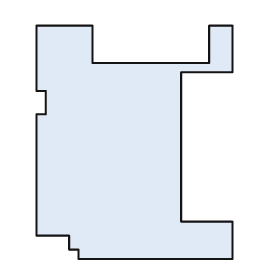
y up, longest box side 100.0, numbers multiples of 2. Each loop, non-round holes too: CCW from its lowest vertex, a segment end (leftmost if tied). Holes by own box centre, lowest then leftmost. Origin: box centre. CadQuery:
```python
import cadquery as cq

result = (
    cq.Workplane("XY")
    .moveTo(-24.0, -50.0)
    .lineTo(42.0, -50.0)
    .lineTo(42.0, -34.0)
    .lineTo(20.0, -34.0)
    .lineTo(20.0, 30.0)
    .lineTo(42.0, 30.0)
    .lineTo(42.0, 50.0)
    .lineTo(32.0, 50.0)
    .lineTo(32.0, 34.0)
    .lineTo(-18.0, 34.0)
    .lineTo(-18.0, 50.0)
    .lineTo(-42.0, 50.0)
    .lineTo(-42.0, 22.0)
    .lineTo(-38.0, 22.0)
    .lineTo(-38.0, 12.0)
    .lineTo(-42.0, 12.0)
    .lineTo(-42.0, -40.0)
    .lineTo(-28.0, -40.0)
    .lineTo(-28.0, -46.0)
    .lineTo(-24.0, -46.0)
    .close()
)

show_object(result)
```